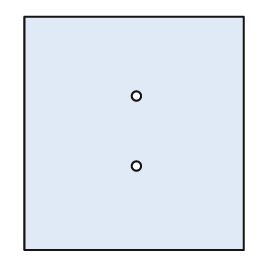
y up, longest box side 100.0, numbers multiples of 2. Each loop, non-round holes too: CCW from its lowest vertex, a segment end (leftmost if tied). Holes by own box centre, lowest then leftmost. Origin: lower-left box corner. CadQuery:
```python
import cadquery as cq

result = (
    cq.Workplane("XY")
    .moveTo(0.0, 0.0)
    .lineTo(94.0, 0.0)
    .lineTo(94.0, 100.0)
    .lineTo(0.0, 100.0)
    .close()
    .moveTo(48.0, 36.0)
    .circle(2.0)
    .moveTo(48.0, 66.0)
    .circle(2.0)
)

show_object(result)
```